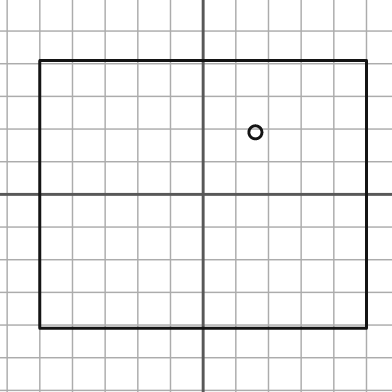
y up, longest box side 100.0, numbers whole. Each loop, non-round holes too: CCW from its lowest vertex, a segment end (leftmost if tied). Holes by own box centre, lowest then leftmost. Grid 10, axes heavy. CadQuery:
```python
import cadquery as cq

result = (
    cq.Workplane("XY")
    .moveTo(-50.0, -41.0)
    .lineTo(50.0, -41.0)
    .lineTo(50.0, 41.0)
    .lineTo(-50.0, 41.0)
    .close()
    .moveTo(16.0, 19.0)
    .circle(2.0)
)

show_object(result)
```